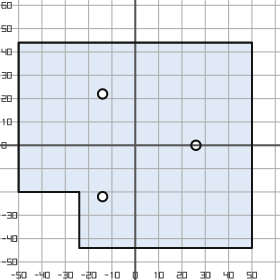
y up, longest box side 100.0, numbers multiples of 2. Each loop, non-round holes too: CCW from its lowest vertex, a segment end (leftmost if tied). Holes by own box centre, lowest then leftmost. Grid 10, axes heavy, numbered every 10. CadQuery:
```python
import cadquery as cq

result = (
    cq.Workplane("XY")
    .moveTo(-24.0, -44.0)
    .lineTo(50.0, -44.0)
    .lineTo(50.0, 44.0)
    .lineTo(-50.0, 44.0)
    .lineTo(-50.0, -20.0)
    .lineTo(-24.0, -20.0)
    .close()
    .moveTo(-14.0, -22.0)
    .circle(2.0)
    .moveTo(26.0, 0.0)
    .circle(2.0)
    .moveTo(-14.0, 22.0)
    .circle(2.0)
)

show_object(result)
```